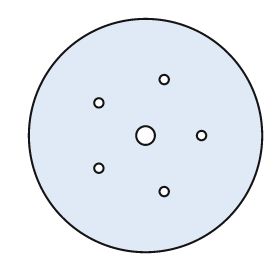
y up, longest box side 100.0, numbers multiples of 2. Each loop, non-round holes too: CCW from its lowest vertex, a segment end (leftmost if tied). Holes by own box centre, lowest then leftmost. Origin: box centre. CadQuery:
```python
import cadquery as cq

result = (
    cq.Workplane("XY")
    .moveTo(0.0, 0.0)
    .circle(50.0)
    .moveTo(8.0, -24.0)
    .circle(2.0)
    .moveTo(-20.0, -14.0)
    .circle(2.0)
    .moveTo(0.0, 0.0)
    .circle(4.0)
    .moveTo(24.0, 0.0)
    .circle(2.0)
    .moveTo(-20.0, 14.0)
    .circle(2.0)
    .moveTo(8.0, 24.0)
    .circle(2.0)
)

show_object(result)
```